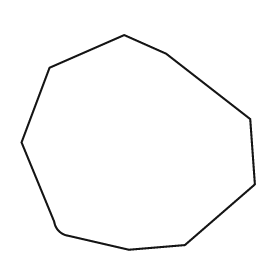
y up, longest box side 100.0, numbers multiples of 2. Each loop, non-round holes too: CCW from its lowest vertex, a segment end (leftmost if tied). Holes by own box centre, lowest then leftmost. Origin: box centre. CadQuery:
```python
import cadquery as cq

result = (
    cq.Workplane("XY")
    .moveTo(-4.0, -46.0)
    .lineTo(20.0, -44.0)
    .lineTo(50.0, -18.0)
    .lineTo(48.0, 10.0)
    .lineTo(12.0, 38.0)
    .lineTo(-6.0, 46.0)
    .lineTo(-38.0, 32.0)
    .lineTo(-50.0, 0.0)
    .lineTo(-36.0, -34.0)
    .threePointArc((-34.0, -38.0), (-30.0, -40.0))
    .close()
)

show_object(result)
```